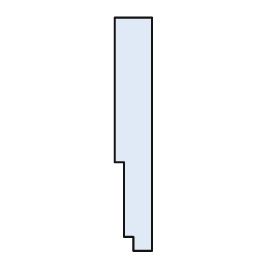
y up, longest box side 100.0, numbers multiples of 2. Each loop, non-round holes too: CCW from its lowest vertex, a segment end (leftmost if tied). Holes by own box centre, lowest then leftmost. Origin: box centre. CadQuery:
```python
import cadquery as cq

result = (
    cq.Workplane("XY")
    .moveTo(0.0, -50.0)
    .lineTo(8.0, -50.0)
    .lineTo(8.0, 50.0)
    .lineTo(-8.0, 50.0)
    .lineTo(-8.0, -12.0)
    .lineTo(-4.0, -12.0)
    .lineTo(-4.0, -44.0)
    .lineTo(0.0, -44.0)
    .close()
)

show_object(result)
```